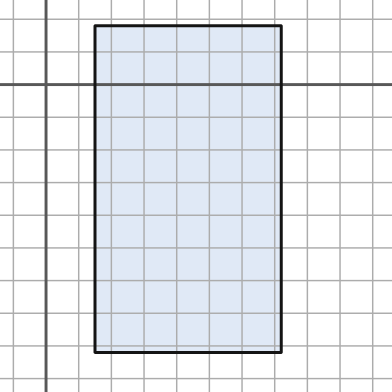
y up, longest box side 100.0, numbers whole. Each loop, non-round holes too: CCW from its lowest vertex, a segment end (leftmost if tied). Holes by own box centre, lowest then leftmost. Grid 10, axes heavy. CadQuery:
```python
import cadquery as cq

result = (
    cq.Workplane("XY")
    .moveTo(15.0, -82.0)
    .lineTo(72.0, -82.0)
    .lineTo(72.0, 18.0)
    .lineTo(15.0, 18.0)
    .close()
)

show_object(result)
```